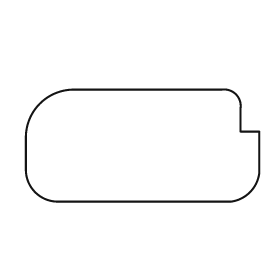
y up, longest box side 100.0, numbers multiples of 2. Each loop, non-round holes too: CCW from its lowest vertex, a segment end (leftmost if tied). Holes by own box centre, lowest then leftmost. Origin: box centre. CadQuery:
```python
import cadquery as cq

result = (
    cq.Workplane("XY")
    .moveTo(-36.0, -24.0)
    .lineTo(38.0, -24.0)
    .threePointArc((46.0, -20.0), (50.0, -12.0))
    .lineTo(50.0, 6.0)
    .lineTo(42.0, 6.0)
    .lineTo(42.0, 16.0)
    .threePointArc((40.0, 22.0), (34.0, 24.0))
    .lineTo(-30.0, 24.0)
    .threePointArc((-44.0, 18.0), (-50.0, 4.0))
    .lineTo(-50.0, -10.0)
    .threePointArc((-46.0, -20.0), (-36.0, -24.0))
    .close()
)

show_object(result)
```